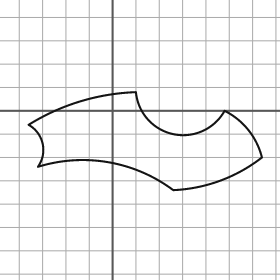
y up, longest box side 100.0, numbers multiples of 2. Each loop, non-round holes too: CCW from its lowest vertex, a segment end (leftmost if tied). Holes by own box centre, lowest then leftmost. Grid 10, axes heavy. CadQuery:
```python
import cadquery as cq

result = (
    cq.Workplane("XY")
    .moveTo(26.0, -34.0)
    .threePointArc((46.0, -30.0), (64.0, -20.0))
    .threePointArc((58.0, -8.0), (48.0, 0.0))
    .threePointArc((26.0, -10.0), (10.0, 8.0))
    .threePointArc((-14.0, 4.0), (-36.0, -6.0))
    .threePointArc((-30.0, -14.0), (-32.0, -24.0))
    .threePointArc((-2.0, -22.0), (26.0, -34.0))
    .close()
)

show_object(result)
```